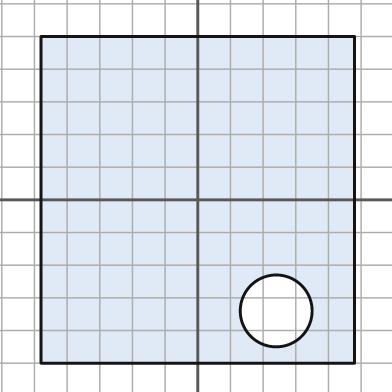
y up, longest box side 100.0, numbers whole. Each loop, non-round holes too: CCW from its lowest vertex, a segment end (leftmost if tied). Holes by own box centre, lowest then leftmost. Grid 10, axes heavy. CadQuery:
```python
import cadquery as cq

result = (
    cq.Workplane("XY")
    .moveTo(-48.0, -50.0)
    .lineTo(48.0, -50.0)
    .lineTo(48.0, 50.0)
    .lineTo(-48.0, 50.0)
    .close()
    .moveTo(24.0, -34.0)
    .circle(11.0)
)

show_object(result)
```